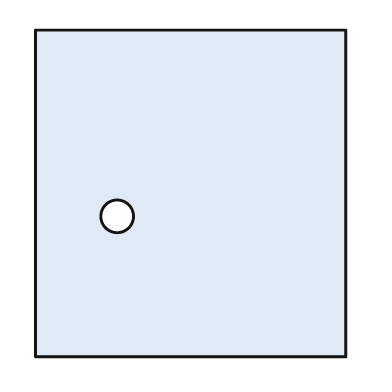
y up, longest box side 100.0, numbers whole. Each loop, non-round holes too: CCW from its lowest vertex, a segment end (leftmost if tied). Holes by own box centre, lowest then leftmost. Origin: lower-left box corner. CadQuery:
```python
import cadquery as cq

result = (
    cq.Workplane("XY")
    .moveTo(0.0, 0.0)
    .lineTo(95.0, 0.0)
    .lineTo(95.0, 100.0)
    .lineTo(0.0, 100.0)
    .close()
    .moveTo(25.0, 43.0)
    .circle(5.0)
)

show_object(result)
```